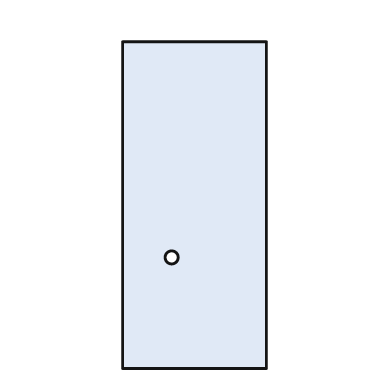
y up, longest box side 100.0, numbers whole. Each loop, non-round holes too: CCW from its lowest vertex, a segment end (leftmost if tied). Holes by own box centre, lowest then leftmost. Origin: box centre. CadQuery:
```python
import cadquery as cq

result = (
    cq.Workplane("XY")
    .moveTo(-22.0, -50.0)
    .lineTo(22.0, -50.0)
    .lineTo(22.0, 50.0)
    .lineTo(-22.0, 50.0)
    .close()
    .moveTo(-7.0, -16.0)
    .circle(2.0)
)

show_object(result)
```